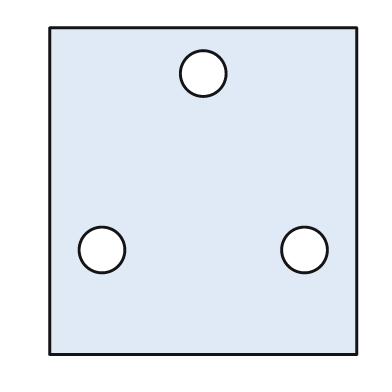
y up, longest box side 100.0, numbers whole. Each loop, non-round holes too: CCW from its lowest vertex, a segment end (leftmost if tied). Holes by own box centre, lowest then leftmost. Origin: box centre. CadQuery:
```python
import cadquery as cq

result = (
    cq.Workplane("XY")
    .moveTo(-47.0, -50.0)
    .lineTo(47.0, -50.0)
    .lineTo(47.0, 50.0)
    .lineTo(-47.0, 50.0)
    .close()
    .moveTo(-31.0, -18.0)
    .circle(7.0)
    .moveTo(31.0, -18.0)
    .circle(7.0)
    .moveTo(0.0, 36.0)
    .circle(7.0)
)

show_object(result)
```